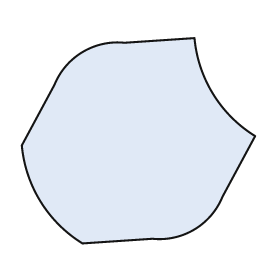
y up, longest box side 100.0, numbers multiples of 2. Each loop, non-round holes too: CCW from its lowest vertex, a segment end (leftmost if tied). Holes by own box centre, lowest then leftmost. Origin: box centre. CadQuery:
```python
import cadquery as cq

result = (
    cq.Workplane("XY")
    .moveTo(-24.0, -44.0)
    .lineTo(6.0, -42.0)
    .threePointArc((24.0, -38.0), (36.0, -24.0))
    .lineTo(50.0, 2.0)
    .threePointArc((32.0, 20.0), (24.0, 44.0))
    .lineTo(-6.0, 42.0)
    .threePointArc((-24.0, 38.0), (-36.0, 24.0))
    .lineTo(-50.0, -2.0)
    .threePointArc((-42.0, -26.0), (-24.0, -44.0))
    .close()
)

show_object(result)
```